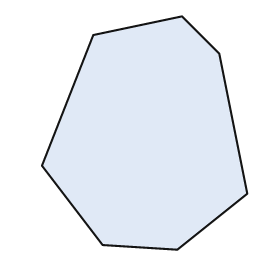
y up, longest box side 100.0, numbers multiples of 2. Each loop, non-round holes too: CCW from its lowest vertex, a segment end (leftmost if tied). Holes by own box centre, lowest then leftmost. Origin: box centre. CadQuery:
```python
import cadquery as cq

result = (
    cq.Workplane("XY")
    .moveTo(14.0, -50.0)
    .lineTo(44.0, -26.0)
    .lineTo(32.0, 34.0)
    .lineTo(16.0, 50.0)
    .lineTo(-22.0, 42.0)
    .lineTo(-44.0, -14.0)
    .lineTo(-18.0, -48.0)
    .close()
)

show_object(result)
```